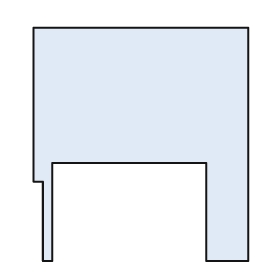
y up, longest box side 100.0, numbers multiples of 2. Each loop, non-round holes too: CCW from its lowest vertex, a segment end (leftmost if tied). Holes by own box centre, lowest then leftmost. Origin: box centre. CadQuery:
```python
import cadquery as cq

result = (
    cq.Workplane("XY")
    .moveTo(-42.0, -50.0)
    .lineTo(-38.0, -50.0)
    .lineTo(-38.0, -8.0)
    .lineTo(28.0, -8.0)
    .lineTo(28.0, -50.0)
    .lineTo(46.0, -50.0)
    .lineTo(46.0, 50.0)
    .lineTo(-46.0, 50.0)
    .lineTo(-46.0, -16.0)
    .lineTo(-42.0, -16.0)
    .close()
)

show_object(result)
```